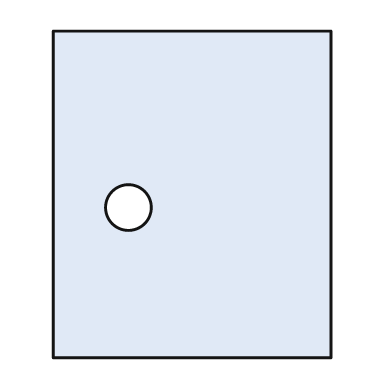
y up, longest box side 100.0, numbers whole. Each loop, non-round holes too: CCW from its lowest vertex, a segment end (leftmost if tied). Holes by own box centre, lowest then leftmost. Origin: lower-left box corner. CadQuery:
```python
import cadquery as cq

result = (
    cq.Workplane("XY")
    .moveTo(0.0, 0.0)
    .lineTo(85.0, 0.0)
    .lineTo(85.0, 100.0)
    .lineTo(0.0, 100.0)
    .close()
    .moveTo(23.0, 46.0)
    .circle(7.0)
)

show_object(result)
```